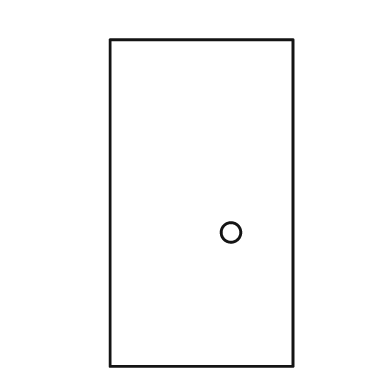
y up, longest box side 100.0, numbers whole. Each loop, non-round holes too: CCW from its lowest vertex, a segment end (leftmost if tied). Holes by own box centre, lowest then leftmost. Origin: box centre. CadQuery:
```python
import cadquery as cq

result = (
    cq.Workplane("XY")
    .moveTo(-28.0, -50.0)
    .lineTo(28.0, -50.0)
    .lineTo(28.0, 50.0)
    .lineTo(-28.0, 50.0)
    .close()
    .moveTo(9.0, -9.0)
    .circle(3.0)
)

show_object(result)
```